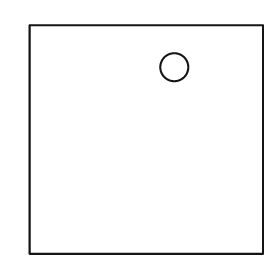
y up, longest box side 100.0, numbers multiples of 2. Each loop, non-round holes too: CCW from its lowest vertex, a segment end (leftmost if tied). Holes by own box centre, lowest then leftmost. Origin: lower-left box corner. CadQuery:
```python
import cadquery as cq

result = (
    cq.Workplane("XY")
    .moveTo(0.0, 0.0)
    .lineTo(100.0, 0.0)
    .lineTo(100.0, 98.0)
    .lineTo(0.0, 98.0)
    .close()
    .moveTo(62.0, 80.0)
    .circle(6.0)
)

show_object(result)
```